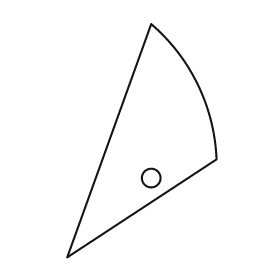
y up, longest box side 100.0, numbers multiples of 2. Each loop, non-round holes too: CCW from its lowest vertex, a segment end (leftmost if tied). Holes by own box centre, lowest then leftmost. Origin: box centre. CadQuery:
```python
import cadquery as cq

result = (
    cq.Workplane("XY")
    .moveTo(-32.0, -50.0)
    .lineTo(32.0, -8.0)
    .threePointArc((24.0, 24.0), (4.0, 50.0))
    .close()
    .moveTo(4.0, -16.0)
    .circle(4.0)
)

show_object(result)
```